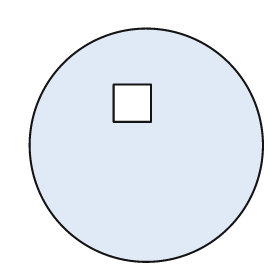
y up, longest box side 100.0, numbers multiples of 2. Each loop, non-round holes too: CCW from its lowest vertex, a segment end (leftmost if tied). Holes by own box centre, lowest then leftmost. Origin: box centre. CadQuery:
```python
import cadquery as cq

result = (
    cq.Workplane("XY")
    .moveTo(0.0, 0.0)
    .circle(50.0)
    .moveTo(-14.0, 10.0)
    .lineTo(2.0, 10.0)
    .lineTo(2.0, 26.0)
    .lineTo(-14.0, 26.0)
    .close()
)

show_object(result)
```